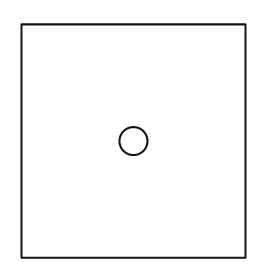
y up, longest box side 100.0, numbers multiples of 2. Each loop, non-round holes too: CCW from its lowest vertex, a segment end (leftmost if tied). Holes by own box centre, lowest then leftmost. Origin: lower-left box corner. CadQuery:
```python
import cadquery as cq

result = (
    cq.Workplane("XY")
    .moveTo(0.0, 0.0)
    .lineTo(96.0, 0.0)
    .lineTo(96.0, 100.0)
    .lineTo(0.0, 100.0)
    .close()
    .moveTo(48.0, 50.0)
    .circle(6.0)
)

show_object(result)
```